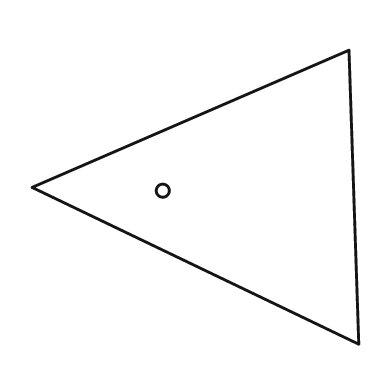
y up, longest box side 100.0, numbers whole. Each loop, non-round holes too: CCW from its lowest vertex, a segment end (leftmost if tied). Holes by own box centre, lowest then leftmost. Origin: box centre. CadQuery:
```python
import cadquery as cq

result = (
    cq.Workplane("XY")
    .moveTo(50.0, -45.0)
    .lineTo(47.0, 45.0)
    .lineTo(-50.0, 3.0)
    .close()
    .moveTo(-10.0, 2.0)
    .circle(2.0)
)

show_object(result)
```